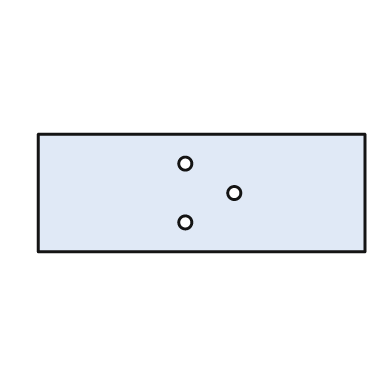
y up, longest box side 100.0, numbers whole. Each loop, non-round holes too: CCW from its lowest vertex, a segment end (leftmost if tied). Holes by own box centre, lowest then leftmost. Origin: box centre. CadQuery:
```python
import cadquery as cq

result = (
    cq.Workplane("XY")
    .moveTo(-50.0, -18.0)
    .lineTo(50.0, -18.0)
    .lineTo(50.0, 18.0)
    .lineTo(-50.0, 18.0)
    .close()
    .moveTo(-5.0, -9.0)
    .circle(2.0)
    .moveTo(10.0, 0.0)
    .circle(2.0)
    .moveTo(-5.0, 9.0)
    .circle(2.0)
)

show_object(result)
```